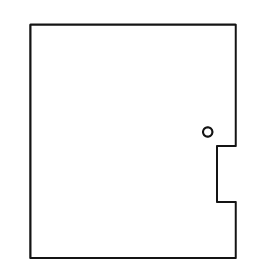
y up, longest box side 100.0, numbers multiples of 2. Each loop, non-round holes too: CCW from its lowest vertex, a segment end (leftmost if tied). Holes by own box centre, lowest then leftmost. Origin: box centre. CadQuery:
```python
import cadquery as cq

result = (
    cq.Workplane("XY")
    .moveTo(-44.0, -50.0)
    .lineTo(44.0, -50.0)
    .lineTo(44.0, -26.0)
    .lineTo(36.0, -26.0)
    .lineTo(36.0, -2.0)
    .lineTo(44.0, -2.0)
    .lineTo(44.0, 50.0)
    .lineTo(-44.0, 50.0)
    .close()
    .moveTo(32.0, 4.0)
    .circle(2.0)
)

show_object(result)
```